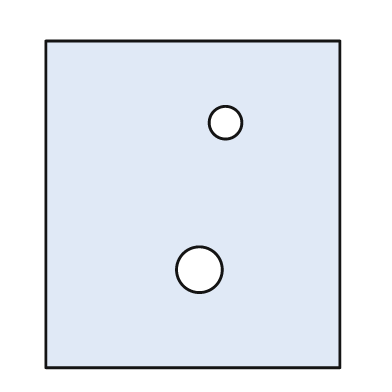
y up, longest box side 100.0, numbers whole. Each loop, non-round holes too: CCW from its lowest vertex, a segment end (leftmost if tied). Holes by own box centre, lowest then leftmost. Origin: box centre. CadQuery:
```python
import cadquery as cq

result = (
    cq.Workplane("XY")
    .moveTo(-45.0, -50.0)
    .lineTo(45.0, -50.0)
    .lineTo(45.0, 50.0)
    .lineTo(-45.0, 50.0)
    .close()
    .moveTo(2.0, -20.0)
    .circle(7.0)
    .moveTo(10.0, 25.0)
    .circle(5.0)
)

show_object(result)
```